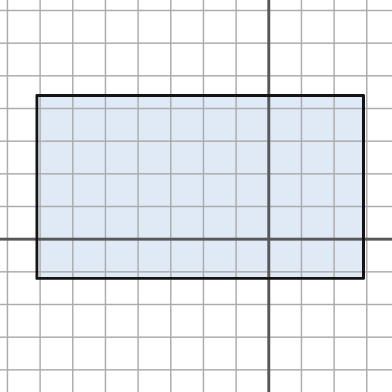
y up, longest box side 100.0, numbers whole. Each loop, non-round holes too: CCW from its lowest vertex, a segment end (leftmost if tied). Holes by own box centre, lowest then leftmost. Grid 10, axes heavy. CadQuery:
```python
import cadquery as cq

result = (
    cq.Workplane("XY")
    .moveTo(-71.0, -12.0)
    .lineTo(29.0, -12.0)
    .lineTo(29.0, 44.0)
    .lineTo(-71.0, 44.0)
    .close()
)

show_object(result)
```